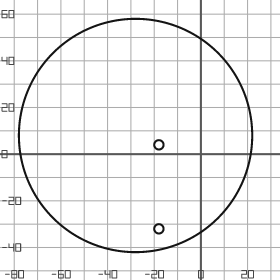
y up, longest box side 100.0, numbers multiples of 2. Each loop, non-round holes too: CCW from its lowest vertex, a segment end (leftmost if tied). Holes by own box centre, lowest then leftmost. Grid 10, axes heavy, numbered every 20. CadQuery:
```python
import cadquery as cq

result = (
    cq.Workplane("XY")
    .moveTo(-28.0, 8.0)
    .circle(50.0)
    .moveTo(-18.0, -32.0)
    .circle(2.0)
    .moveTo(-18.0, 4.0)
    .circle(2.0)
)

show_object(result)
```